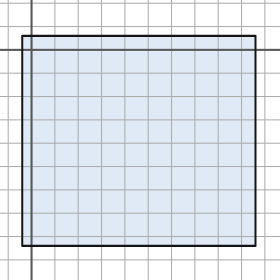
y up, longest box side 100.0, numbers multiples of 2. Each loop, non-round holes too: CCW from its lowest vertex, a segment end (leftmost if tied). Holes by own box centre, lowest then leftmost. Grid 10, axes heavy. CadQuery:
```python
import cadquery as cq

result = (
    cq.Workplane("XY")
    .moveTo(-4.0, -84.0)
    .lineTo(96.0, -84.0)
    .lineTo(96.0, 6.0)
    .lineTo(-4.0, 6.0)
    .close()
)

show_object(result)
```